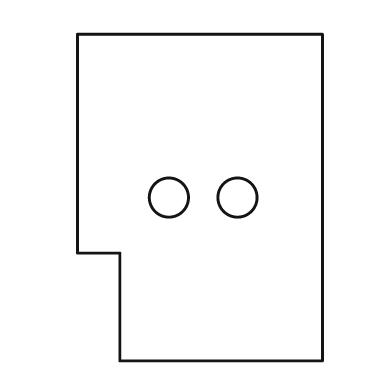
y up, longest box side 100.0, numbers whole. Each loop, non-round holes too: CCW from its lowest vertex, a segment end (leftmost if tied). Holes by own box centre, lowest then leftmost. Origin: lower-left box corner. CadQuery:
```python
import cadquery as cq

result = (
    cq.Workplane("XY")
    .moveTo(13.0, 0.0)
    .lineTo(75.0, 0.0)
    .lineTo(75.0, 100.0)
    .lineTo(0.0, 100.0)
    .lineTo(0.0, 33.0)
    .lineTo(13.0, 33.0)
    .close()
    .moveTo(28.0, 50.0)
    .circle(6.0)
    .moveTo(49.0, 50.0)
    .circle(6.0)
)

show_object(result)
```